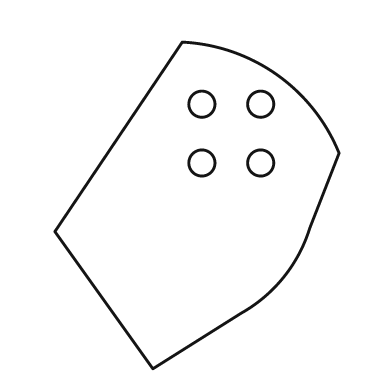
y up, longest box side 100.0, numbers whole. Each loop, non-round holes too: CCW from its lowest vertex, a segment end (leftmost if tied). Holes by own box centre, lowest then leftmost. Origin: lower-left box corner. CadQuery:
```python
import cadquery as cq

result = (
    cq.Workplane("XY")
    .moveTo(30.0, 0.0)
    .lineTo(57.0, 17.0)
    .threePointArc((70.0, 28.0), (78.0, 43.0))
    .lineTo(87.0, 66.0)
    .threePointArc((68.0, 90.0), (39.0, 100.0))
    .lineTo(0.0, 42.0)
    .close()
    .moveTo(45.0, 63.0)
    .circle(4.0)
    .moveTo(63.0, 63.0)
    .circle(4.0)
    .moveTo(45.0, 81.0)
    .circle(4.0)
    .moveTo(63.0, 81.0)
    .circle(4.0)
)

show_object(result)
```